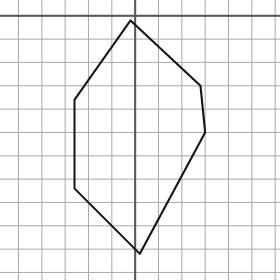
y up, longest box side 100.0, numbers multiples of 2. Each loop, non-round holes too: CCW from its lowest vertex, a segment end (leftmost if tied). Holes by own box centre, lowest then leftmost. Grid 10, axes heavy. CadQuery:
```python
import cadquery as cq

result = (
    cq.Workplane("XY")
    .moveTo(2.0, -102.0)
    .lineTo(30.0, -50.0)
    .lineTo(28.0, -30.0)
    .lineTo(-2.0, -2.0)
    .lineTo(-26.0, -36.0)
    .lineTo(-26.0, -74.0)
    .close()
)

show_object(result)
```